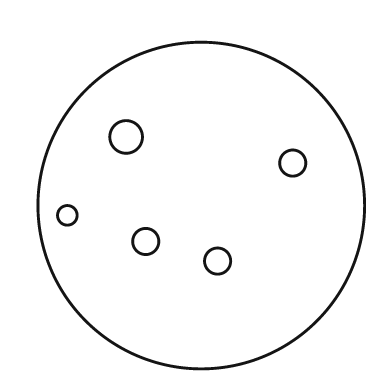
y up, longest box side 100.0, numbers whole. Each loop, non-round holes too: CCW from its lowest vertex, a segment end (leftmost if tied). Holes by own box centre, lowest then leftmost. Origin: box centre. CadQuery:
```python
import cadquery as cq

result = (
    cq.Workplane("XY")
    .moveTo(0.0, 0.0)
    .circle(50.0)
    .moveTo(5.0, -17.0)
    .circle(4.0)
    .moveTo(-17.0, -11.0)
    .circle(4.0)
    .moveTo(-41.0, -3.0)
    .circle(3.0)
    .moveTo(28.0, 13.0)
    .circle(4.0)
    .moveTo(-23.0, 21.0)
    .circle(5.0)
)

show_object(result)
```